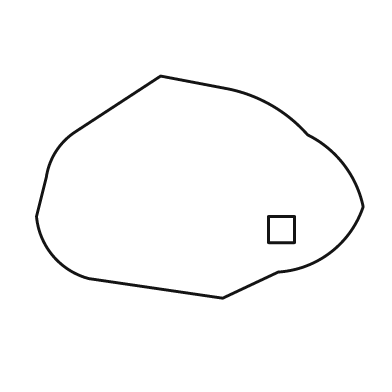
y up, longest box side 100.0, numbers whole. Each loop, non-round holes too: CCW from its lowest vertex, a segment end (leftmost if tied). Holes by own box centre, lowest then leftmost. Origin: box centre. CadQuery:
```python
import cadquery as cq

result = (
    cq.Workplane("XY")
    .moveTo(7.0, -34.0)
    .lineTo(24.0, -26.0)
    .threePointArc((40.0, -20.0), (50.0, -6.0))
    .threePointArc((44.0, 7.0), (33.0, 16.0))
    .threePointArc((22.0, 25.0), (9.0, 30.0))
    .lineTo(-12.0, 34.0)
    .lineTo(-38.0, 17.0)
    .threePointArc((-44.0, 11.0), (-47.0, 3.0))
    .lineTo(-50.0, -9.0)
    .threePointArc((-45.0, -21.0), (-34.0, -28.0))
    .close()
    .moveTo(21.0, -17.0)
    .lineTo(29.0, -17.0)
    .lineTo(29.0, -9.0)
    .lineTo(21.0, -9.0)
    .close()
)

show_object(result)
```